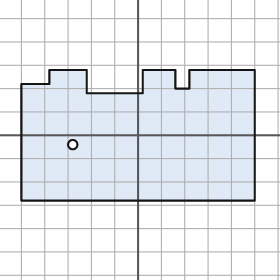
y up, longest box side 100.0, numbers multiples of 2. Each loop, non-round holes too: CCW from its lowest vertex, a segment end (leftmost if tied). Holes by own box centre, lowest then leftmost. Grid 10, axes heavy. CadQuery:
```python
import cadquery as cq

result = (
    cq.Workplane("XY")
    .moveTo(-50.0, -28.0)
    .lineTo(50.0, -28.0)
    .lineTo(50.0, 28.0)
    .lineTo(22.0, 28.0)
    .lineTo(22.0, 20.0)
    .lineTo(16.0, 20.0)
    .lineTo(16.0, 28.0)
    .lineTo(2.0, 28.0)
    .lineTo(2.0, 18.0)
    .lineTo(-22.0, 18.0)
    .lineTo(-22.0, 28.0)
    .lineTo(-38.0, 28.0)
    .lineTo(-38.0, 22.0)
    .lineTo(-50.0, 22.0)
    .close()
    .moveTo(-28.0, -4.0)
    .circle(2.0)
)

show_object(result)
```